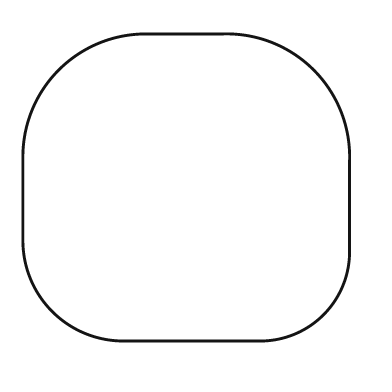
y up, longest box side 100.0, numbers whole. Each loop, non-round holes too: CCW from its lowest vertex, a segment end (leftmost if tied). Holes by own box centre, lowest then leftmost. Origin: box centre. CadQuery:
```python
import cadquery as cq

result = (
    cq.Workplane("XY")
    .moveTo(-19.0, -47.0)
    .lineTo(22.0, -47.0)
    .threePointArc((42.0, -39.0), (50.0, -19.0))
    .lineTo(50.0, 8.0)
    .threePointArc((39.0, 36.0), (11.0, 47.0))
    .lineTo(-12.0, 47.0)
    .threePointArc((-39.0, 36.0), (-50.0, 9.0))
    .lineTo(-50.0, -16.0)
    .threePointArc((-41.0, -38.0), (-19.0, -47.0))
    .close()
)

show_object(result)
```